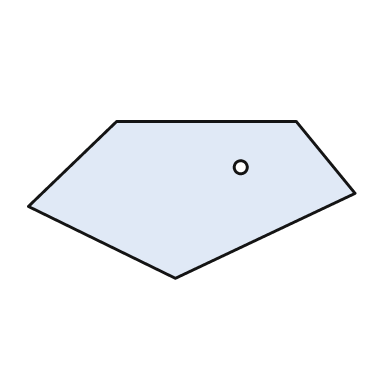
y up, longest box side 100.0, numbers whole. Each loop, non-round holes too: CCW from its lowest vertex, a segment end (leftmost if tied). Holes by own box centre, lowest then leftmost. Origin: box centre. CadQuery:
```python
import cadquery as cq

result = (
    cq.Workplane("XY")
    .moveTo(-5.0, -24.0)
    .lineTo(50.0, 2.0)
    .lineTo(32.0, 24.0)
    .lineTo(-23.0, 24.0)
    .lineTo(-50.0, -2.0)
    .close()
    .moveTo(15.0, 10.0)
    .circle(2.0)
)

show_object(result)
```